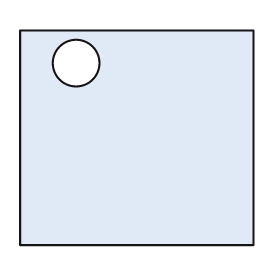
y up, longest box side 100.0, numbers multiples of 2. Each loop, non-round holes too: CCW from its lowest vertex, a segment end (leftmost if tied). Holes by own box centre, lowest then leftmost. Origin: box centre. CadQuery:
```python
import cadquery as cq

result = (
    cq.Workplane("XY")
    .moveTo(-50.0, -46.0)
    .lineTo(50.0, -46.0)
    .lineTo(50.0, 46.0)
    .lineTo(-50.0, 46.0)
    .close()
    .moveTo(-26.0, 32.0)
    .circle(10.0)
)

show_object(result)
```